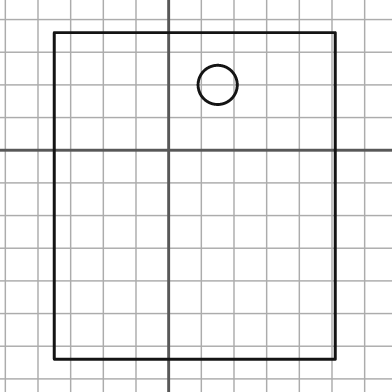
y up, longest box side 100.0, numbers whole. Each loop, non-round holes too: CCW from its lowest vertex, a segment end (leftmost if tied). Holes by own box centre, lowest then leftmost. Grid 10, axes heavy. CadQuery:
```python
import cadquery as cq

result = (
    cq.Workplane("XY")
    .moveTo(-35.0, -64.0)
    .lineTo(51.0, -64.0)
    .lineTo(51.0, 36.0)
    .lineTo(-35.0, 36.0)
    .close()
    .moveTo(15.0, 20.0)
    .circle(6.0)
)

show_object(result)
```